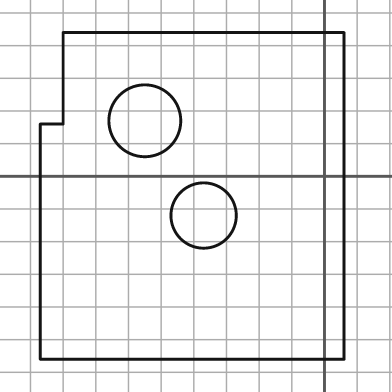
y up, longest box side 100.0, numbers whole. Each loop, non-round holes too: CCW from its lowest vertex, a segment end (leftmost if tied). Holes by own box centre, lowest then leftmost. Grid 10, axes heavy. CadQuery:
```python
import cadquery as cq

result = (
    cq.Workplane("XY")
    .moveTo(-87.0, -56.0)
    .lineTo(6.0, -56.0)
    .lineTo(6.0, 44.0)
    .lineTo(-80.0, 44.0)
    .lineTo(-80.0, 16.0)
    .lineTo(-87.0, 16.0)
    .close()
    .moveTo(-37.0, -12.0)
    .circle(10.0)
    .moveTo(-55.0, 17.0)
    .circle(11.0)
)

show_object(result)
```